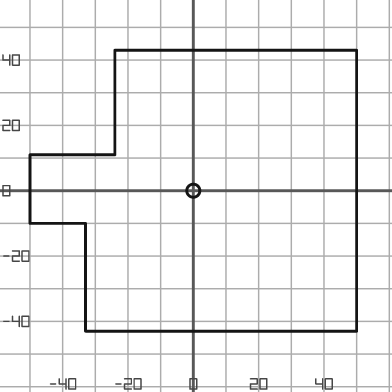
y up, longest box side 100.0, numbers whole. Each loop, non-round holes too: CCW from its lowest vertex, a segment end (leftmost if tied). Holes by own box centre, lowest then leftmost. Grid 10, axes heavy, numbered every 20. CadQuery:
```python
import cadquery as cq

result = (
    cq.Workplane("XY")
    .moveTo(-33.0, -43.0)
    .lineTo(50.0, -43.0)
    .lineTo(50.0, 43.0)
    .lineTo(-24.0, 43.0)
    .lineTo(-24.0, 11.0)
    .lineTo(-50.0, 11.0)
    .lineTo(-50.0, -10.0)
    .lineTo(-33.0, -10.0)
    .close()
    .moveTo(0.0, 0.0)
    .circle(2.0)
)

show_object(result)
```